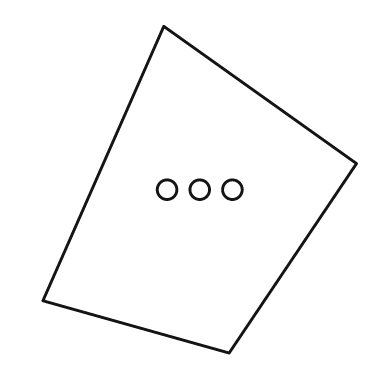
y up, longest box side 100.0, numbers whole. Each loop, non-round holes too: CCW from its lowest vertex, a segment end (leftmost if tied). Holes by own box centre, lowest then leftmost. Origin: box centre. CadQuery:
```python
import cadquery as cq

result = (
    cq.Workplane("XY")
    .moveTo(9.0, -50.0)
    .lineTo(48.0, 8.0)
    .lineTo(-11.0, 50.0)
    .lineTo(-48.0, -34.0)
    .close()
    .moveTo(-10.0, 0.0)
    .circle(3.0)
    .moveTo(0.0, 0.0)
    .circle(3.0)
    .moveTo(10.0, 0.0)
    .circle(3.0)
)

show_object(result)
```